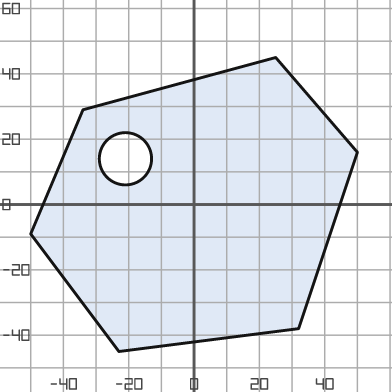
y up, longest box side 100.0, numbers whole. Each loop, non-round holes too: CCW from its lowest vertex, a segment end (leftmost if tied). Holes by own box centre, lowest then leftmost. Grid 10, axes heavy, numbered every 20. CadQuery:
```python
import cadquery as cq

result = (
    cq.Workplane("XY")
    .moveTo(-23.0, -45.0)
    .lineTo(32.0, -38.0)
    .lineTo(50.0, 16.0)
    .lineTo(25.0, 45.0)
    .lineTo(-34.0, 29.0)
    .lineTo(-50.0, -9.0)
    .close()
    .moveTo(-21.0, 14.0)
    .circle(8.0)
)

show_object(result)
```